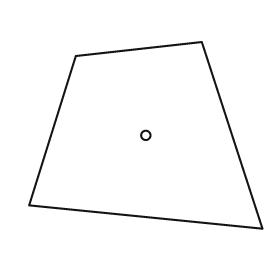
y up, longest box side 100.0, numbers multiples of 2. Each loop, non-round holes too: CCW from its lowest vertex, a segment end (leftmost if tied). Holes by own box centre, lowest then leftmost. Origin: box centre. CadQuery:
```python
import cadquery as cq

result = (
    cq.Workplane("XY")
    .moveTo(50.0, -40.0)
    .lineTo(24.0, 40.0)
    .lineTo(-30.0, 34.0)
    .lineTo(-50.0, -30.0)
    .close()
    .moveTo(0.0, 0.0)
    .circle(2.0)
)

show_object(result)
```